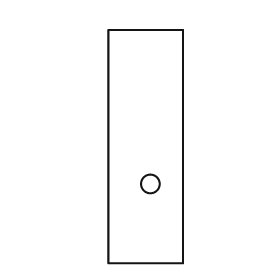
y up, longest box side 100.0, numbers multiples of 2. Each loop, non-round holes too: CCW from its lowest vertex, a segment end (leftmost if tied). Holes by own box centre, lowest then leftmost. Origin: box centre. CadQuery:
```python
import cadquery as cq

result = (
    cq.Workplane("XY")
    .moveTo(-16.0, -50.0)
    .lineTo(16.0, -50.0)
    .lineTo(16.0, 50.0)
    .lineTo(-16.0, 50.0)
    .close()
    .moveTo(2.0, -16.0)
    .circle(4.0)
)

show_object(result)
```